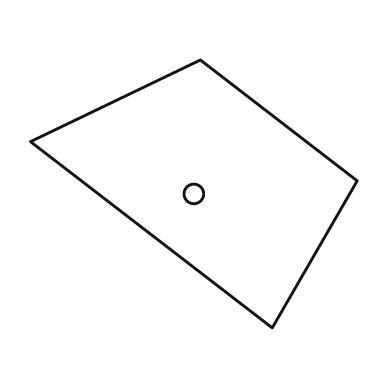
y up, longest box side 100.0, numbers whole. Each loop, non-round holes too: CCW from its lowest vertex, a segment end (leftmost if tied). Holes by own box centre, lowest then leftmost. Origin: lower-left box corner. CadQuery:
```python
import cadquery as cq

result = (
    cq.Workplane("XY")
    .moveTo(74.0, 0.0)
    .lineTo(100.0, 45.0)
    .lineTo(52.0, 82.0)
    .lineTo(0.0, 57.0)
    .close()
    .moveTo(50.0, 41.0)
    .circle(3.0)
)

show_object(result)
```